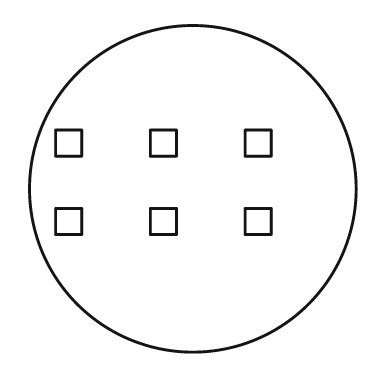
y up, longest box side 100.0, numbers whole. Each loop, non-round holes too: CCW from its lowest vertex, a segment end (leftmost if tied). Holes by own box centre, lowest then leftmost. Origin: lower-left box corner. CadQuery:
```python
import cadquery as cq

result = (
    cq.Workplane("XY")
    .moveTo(50.0, 50.0)
    .circle(50.0)
    .moveTo(8.0, 36.0)
    .lineTo(16.0, 36.0)
    .lineTo(16.0, 44.0)
    .lineTo(8.0, 44.0)
    .close()
    .moveTo(37.0, 36.0)
    .lineTo(45.0, 36.0)
    .lineTo(45.0, 44.0)
    .lineTo(37.0, 44.0)
    .close()
    .moveTo(66.0, 36.0)
    .lineTo(74.0, 36.0)
    .lineTo(74.0, 44.0)
    .lineTo(66.0, 44.0)
    .close()
    .moveTo(8.0, 60.0)
    .lineTo(16.0, 60.0)
    .lineTo(16.0, 68.0)
    .lineTo(8.0, 68.0)
    .close()
    .moveTo(37.0, 60.0)
    .lineTo(45.0, 60.0)
    .lineTo(45.0, 68.0)
    .lineTo(37.0, 68.0)
    .close()
    .moveTo(66.0, 60.0)
    .lineTo(74.0, 60.0)
    .lineTo(74.0, 68.0)
    .lineTo(66.0, 68.0)
    .close()
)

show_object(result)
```